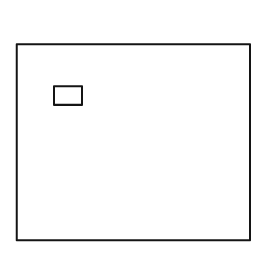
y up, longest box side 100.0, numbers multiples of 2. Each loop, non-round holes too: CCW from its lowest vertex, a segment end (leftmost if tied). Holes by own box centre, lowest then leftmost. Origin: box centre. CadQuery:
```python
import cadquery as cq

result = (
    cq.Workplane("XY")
    .moveTo(-50.0, -42.0)
    .lineTo(50.0, -42.0)
    .lineTo(50.0, 42.0)
    .lineTo(-50.0, 42.0)
    .close()
    .moveTo(-34.0, 16.0)
    .lineTo(-22.0, 16.0)
    .lineTo(-22.0, 24.0)
    .lineTo(-34.0, 24.0)
    .close()
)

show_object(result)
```